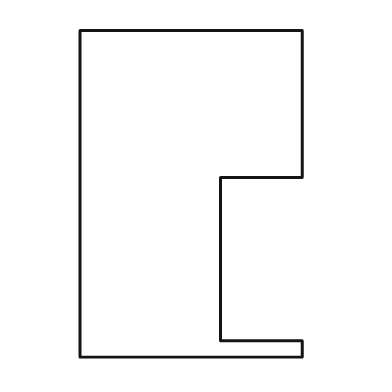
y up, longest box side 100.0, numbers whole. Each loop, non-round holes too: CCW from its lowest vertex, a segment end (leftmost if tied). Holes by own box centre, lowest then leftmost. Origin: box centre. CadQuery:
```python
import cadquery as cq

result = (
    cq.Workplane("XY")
    .moveTo(-34.0, -50.0)
    .lineTo(34.0, -50.0)
    .lineTo(34.0, -45.0)
    .lineTo(9.0, -45.0)
    .lineTo(9.0, 5.0)
    .lineTo(34.0, 5.0)
    .lineTo(34.0, 50.0)
    .lineTo(-34.0, 50.0)
    .close()
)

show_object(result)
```